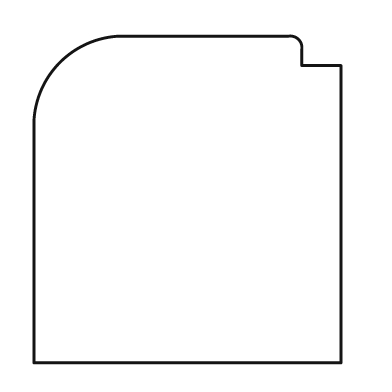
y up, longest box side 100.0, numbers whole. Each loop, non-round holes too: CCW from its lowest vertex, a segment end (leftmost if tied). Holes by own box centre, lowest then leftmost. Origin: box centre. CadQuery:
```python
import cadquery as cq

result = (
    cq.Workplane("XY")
    .moveTo(-47.0, -50.0)
    .lineTo(47.0, -50.0)
    .lineTo(47.0, 41.0)
    .lineTo(35.0, 41.0)
    .lineTo(35.0, 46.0)
    .threePointArc((34.0, 49.0), (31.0, 50.0))
    .lineTo(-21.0, 50.0)
    .threePointArc((-39.0, 42.0), (-47.0, 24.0))
    .close()
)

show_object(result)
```